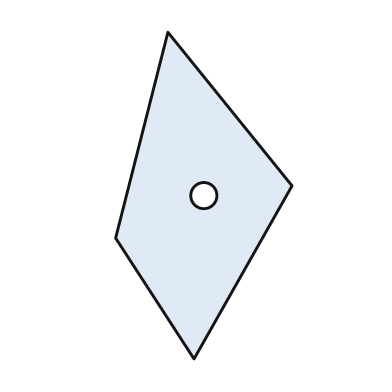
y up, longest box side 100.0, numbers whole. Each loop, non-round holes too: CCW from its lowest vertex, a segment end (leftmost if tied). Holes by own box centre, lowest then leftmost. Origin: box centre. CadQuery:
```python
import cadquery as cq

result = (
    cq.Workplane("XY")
    .moveTo(-3.0, -50.0)
    .lineTo(27.0, 3.0)
    .lineTo(-11.0, 50.0)
    .lineTo(-27.0, -13.0)
    .close()
    .moveTo(0.0, 0.0)
    .circle(4.0)
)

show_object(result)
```